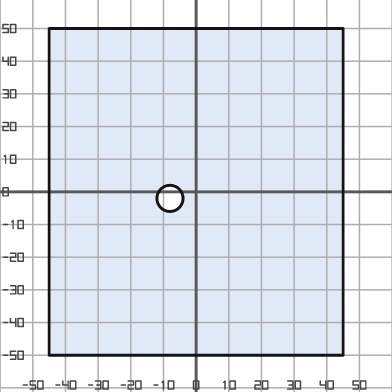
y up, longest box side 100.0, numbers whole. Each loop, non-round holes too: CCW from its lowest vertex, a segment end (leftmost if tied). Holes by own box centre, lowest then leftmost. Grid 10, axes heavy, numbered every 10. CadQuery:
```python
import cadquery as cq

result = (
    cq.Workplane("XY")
    .moveTo(-45.0, -50.0)
    .lineTo(45.0, -50.0)
    .lineTo(45.0, 50.0)
    .lineTo(-45.0, 50.0)
    .close()
    .moveTo(-8.0, -2.0)
    .circle(4.0)
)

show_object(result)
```